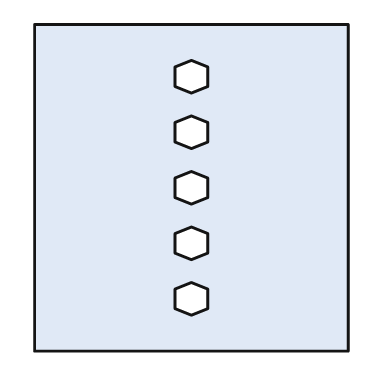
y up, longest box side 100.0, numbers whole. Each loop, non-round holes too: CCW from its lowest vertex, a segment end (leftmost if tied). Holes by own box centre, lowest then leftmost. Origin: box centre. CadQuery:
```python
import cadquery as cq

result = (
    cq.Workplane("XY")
    .moveTo(-48.0, -50.0)
    .lineTo(48.0, -50.0)
    .lineTo(48.0, 50.0)
    .lineTo(-48.0, 50.0)
    .close()
    .moveTo(0.0, -39.0)
    .lineTo(5.0, -37.0)
    .lineTo(5.0, -31.0)
    .lineTo(0.0, -29.0)
    .lineTo(-5.0, -31.0)
    .lineTo(-5.0, -37.0)
    .close()
    .moveTo(0.0, -22.0)
    .lineTo(5.0, -20.0)
    .lineTo(5.0, -14.0)
    .lineTo(0.0, -12.0)
    .lineTo(-5.0, -14.0)
    .lineTo(-5.0, -20.0)
    .close()
    .moveTo(0.0, -5.0)
    .lineTo(5.0, -3.0)
    .lineTo(5.0, 3.0)
    .lineTo(0.0, 5.0)
    .lineTo(-5.0, 3.0)
    .lineTo(-5.0, -3.0)
    .close()
    .moveTo(0.0, 12.0)
    .lineTo(5.0, 14.0)
    .lineTo(5.0, 20.0)
    .lineTo(0.0, 22.0)
    .lineTo(-5.0, 20.0)
    .lineTo(-5.0, 14.0)
    .close()
    .moveTo(0.0, 29.0)
    .lineTo(5.0, 31.0)
    .lineTo(5.0, 37.0)
    .lineTo(0.0, 39.0)
    .lineTo(-5.0, 37.0)
    .lineTo(-5.0, 31.0)
    .close()
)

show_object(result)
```